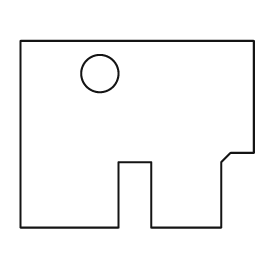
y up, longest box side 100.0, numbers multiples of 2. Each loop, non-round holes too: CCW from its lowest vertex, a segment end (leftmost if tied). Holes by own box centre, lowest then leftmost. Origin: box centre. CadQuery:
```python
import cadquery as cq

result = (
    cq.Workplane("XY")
    .moveTo(-50.0, -40.0)
    .lineTo(-8.0, -40.0)
    .lineTo(-8.0, -12.0)
    .lineTo(6.0, -12.0)
    .lineTo(6.0, -40.0)
    .lineTo(36.0, -40.0)
    .lineTo(36.0, -12.0)
    .lineTo(40.0, -8.0)
    .lineTo(50.0, -8.0)
    .lineTo(50.0, 40.0)
    .lineTo(-50.0, 40.0)
    .close()
    .moveTo(-16.0, 26.0)
    .circle(8.0)
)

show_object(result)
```